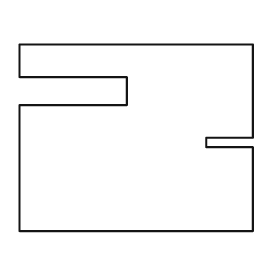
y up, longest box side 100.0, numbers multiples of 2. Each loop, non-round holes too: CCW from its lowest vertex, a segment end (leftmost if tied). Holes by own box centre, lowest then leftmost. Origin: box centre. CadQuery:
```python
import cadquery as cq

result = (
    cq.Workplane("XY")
    .moveTo(-50.0, -40.0)
    .lineTo(50.0, -40.0)
    .lineTo(50.0, -4.0)
    .lineTo(30.0, -4.0)
    .lineTo(30.0, 0.0)
    .lineTo(50.0, 0.0)
    .lineTo(50.0, 40.0)
    .lineTo(-50.0, 40.0)
    .lineTo(-50.0, 26.0)
    .lineTo(-4.0, 26.0)
    .lineTo(-4.0, 14.0)
    .lineTo(-50.0, 14.0)
    .close()
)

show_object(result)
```